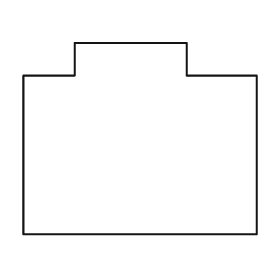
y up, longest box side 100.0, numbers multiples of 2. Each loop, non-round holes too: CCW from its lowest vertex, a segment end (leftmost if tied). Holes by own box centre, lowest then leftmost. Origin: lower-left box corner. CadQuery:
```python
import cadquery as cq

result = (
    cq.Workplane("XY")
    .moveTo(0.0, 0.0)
    .lineTo(100.0, 0.0)
    .lineTo(100.0, 68.0)
    .lineTo(70.0, 68.0)
    .lineTo(70.0, 82.0)
    .lineTo(22.0, 82.0)
    .lineTo(22.0, 68.0)
    .lineTo(0.0, 68.0)
    .close()
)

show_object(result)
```